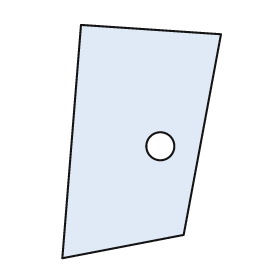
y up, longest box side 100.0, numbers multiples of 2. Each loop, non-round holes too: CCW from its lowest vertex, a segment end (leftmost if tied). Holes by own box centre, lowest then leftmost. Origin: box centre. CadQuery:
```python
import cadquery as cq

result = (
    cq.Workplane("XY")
    .moveTo(-34.0, -50.0)
    .lineTo(18.0, -40.0)
    .lineTo(34.0, 46.0)
    .lineTo(-26.0, 50.0)
    .close()
    .moveTo(8.0, -2.0)
    .circle(6.0)
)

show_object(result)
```